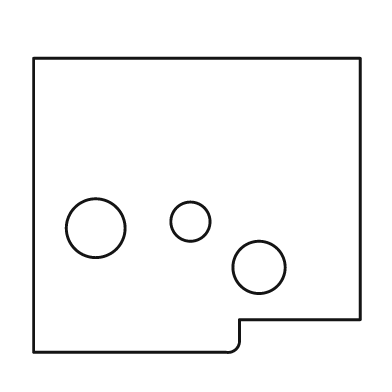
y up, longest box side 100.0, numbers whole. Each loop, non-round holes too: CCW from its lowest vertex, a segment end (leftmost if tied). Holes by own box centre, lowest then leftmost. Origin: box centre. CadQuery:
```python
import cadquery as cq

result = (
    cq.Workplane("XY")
    .moveTo(-50.0, -45.0)
    .lineTo(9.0, -45.0)
    .threePointArc((12.0, -44.0), (13.0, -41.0))
    .lineTo(13.0, -35.0)
    .lineTo(50.0, -35.0)
    .lineTo(50.0, 45.0)
    .lineTo(-50.0, 45.0)
    .close()
    .moveTo(19.0, -19.0)
    .circle(8.0)
    .moveTo(-31.0, -7.0)
    .circle(9.0)
    .moveTo(-2.0, -5.0)
    .circle(6.0)
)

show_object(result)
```